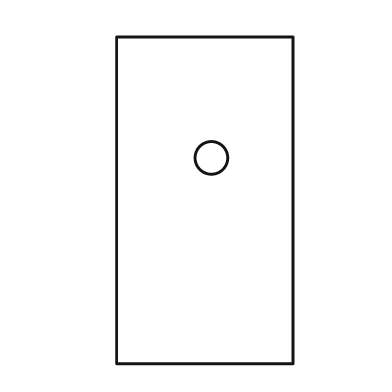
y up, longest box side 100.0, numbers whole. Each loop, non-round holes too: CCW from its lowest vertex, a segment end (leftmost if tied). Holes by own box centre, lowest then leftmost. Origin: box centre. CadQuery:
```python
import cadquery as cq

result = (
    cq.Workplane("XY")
    .moveTo(-27.0, -50.0)
    .lineTo(27.0, -50.0)
    .lineTo(27.0, 50.0)
    .lineTo(-27.0, 50.0)
    .close()
    .moveTo(2.0, 13.0)
    .circle(5.0)
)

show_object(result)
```